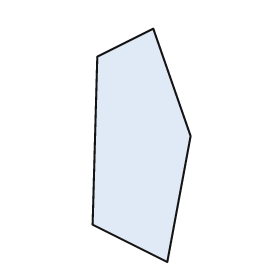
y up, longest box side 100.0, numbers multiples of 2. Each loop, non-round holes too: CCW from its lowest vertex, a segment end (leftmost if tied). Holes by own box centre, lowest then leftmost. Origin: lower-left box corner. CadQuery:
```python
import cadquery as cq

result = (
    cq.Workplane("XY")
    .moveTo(32.0, 0.0)
    .lineTo(42.0, 54.0)
    .lineTo(26.0, 100.0)
    .lineTo(2.0, 88.0)
    .lineTo(0.0, 16.0)
    .close()
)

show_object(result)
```